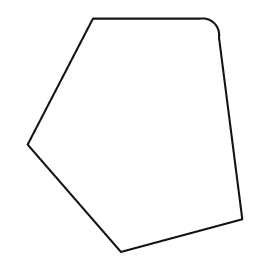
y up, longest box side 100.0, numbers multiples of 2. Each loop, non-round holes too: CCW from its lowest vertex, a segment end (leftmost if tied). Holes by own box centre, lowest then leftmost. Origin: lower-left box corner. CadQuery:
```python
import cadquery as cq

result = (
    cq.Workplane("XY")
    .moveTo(40.0, 0.0)
    .lineTo(92.0, 14.0)
    .lineTo(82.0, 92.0)
    .threePointArc((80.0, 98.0), (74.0, 100.0))
    .lineTo(28.0, 100.0)
    .lineTo(0.0, 46.0)
    .close()
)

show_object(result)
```